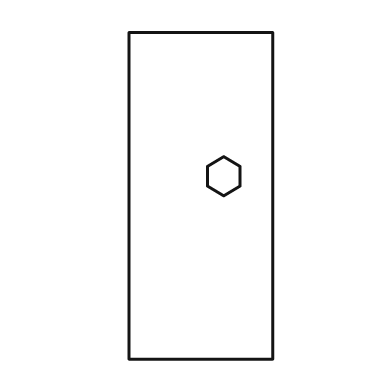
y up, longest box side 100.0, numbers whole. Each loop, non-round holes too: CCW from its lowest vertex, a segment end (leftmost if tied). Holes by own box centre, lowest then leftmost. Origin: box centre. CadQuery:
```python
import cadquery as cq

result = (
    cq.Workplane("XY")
    .moveTo(-22.0, -50.0)
    .lineTo(22.0, -50.0)
    .lineTo(22.0, 50.0)
    .lineTo(-22.0, 50.0)
    .close()
    .moveTo(7.0, 0.0)
    .lineTo(12.0, 3.0)
    .lineTo(12.0, 9.0)
    .lineTo(7.0, 12.0)
    .lineTo(2.0, 9.0)
    .lineTo(2.0, 3.0)
    .close()
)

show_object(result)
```